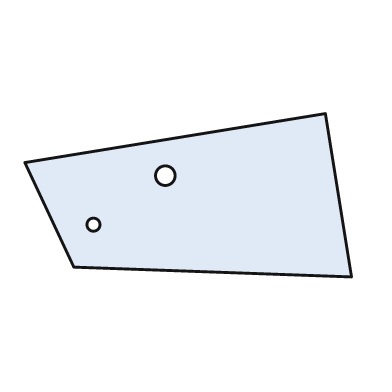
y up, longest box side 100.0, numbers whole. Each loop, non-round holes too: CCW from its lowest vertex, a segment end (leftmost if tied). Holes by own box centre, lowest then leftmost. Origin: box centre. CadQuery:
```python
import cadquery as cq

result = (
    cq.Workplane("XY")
    .moveTo(50.0, -25.0)
    .lineTo(42.0, 25.0)
    .lineTo(-50.0, 10.0)
    .lineTo(-35.0, -22.0)
    .close()
    .moveTo(-29.0, -9.0)
    .circle(2.0)
    .moveTo(-7.0, 6.0)
    .circle(3.0)
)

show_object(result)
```